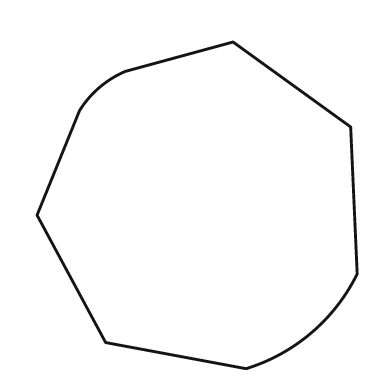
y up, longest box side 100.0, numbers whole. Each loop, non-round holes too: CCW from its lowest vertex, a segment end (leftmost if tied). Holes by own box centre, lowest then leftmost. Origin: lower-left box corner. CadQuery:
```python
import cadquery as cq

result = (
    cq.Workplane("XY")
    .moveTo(64.0, 0.0)
    .threePointArc((84.0, 11.0), (98.0, 29.0))
    .lineTo(96.0, 74.0)
    .lineTo(60.0, 100.0)
    .lineTo(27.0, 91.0)
    .threePointArc((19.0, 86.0), (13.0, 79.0))
    .lineTo(0.0, 47.0)
    .lineTo(21.0, 8.0)
    .close()
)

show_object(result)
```